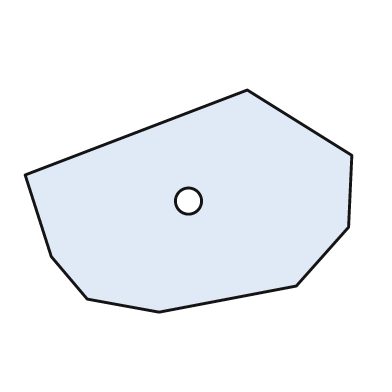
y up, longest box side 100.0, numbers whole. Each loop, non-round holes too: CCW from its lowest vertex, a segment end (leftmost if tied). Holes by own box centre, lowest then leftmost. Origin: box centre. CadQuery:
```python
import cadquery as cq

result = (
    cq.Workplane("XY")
    .moveTo(-9.0, -34.0)
    .lineTo(33.0, -26.0)
    .lineTo(49.0, -8.0)
    .lineTo(50.0, 14.0)
    .lineTo(18.0, 34.0)
    .lineTo(-50.0, 8.0)
    .lineTo(-42.0, -17.0)
    .lineTo(-31.0, -30.0)
    .close()
    .moveTo(0.0, 0.0)
    .circle(4.0)
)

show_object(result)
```